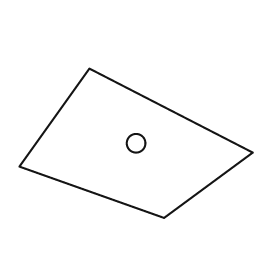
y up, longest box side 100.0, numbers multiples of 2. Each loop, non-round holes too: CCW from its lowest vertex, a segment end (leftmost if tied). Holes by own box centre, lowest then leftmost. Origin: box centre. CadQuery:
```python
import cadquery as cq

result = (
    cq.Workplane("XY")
    .moveTo(12.0, -32.0)
    .lineTo(50.0, -4.0)
    .lineTo(-20.0, 32.0)
    .lineTo(-50.0, -10.0)
    .close()
    .moveTo(0.0, 0.0)
    .circle(4.0)
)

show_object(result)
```